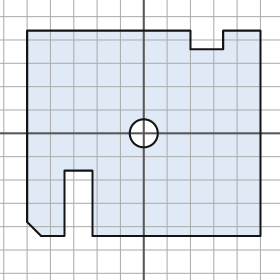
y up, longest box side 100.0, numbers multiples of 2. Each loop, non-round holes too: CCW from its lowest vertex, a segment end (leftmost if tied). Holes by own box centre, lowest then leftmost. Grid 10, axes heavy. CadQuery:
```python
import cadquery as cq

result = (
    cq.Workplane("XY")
    .moveTo(-44.0, -44.0)
    .lineTo(-34.0, -44.0)
    .lineTo(-34.0, -16.0)
    .lineTo(-22.0, -16.0)
    .lineTo(-22.0, -44.0)
    .lineTo(50.0, -44.0)
    .lineTo(50.0, 44.0)
    .lineTo(34.0, 44.0)
    .lineTo(34.0, 36.0)
    .lineTo(20.0, 36.0)
    .lineTo(20.0, 44.0)
    .lineTo(-50.0, 44.0)
    .lineTo(-50.0, -38.0)
    .close()
    .moveTo(0.0, 0.0)
    .circle(6.0)
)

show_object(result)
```